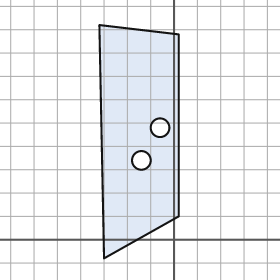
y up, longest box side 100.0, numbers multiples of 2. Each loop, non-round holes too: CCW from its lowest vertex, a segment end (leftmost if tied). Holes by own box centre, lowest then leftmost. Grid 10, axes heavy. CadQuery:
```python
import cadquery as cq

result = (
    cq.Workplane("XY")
    .moveTo(-30.0, -8.0)
    .lineTo(2.0, 10.0)
    .lineTo(2.0, 88.0)
    .lineTo(-32.0, 92.0)
    .close()
    .moveTo(-14.0, 34.0)
    .circle(4.0)
    .moveTo(-6.0, 48.0)
    .circle(4.0)
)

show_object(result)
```